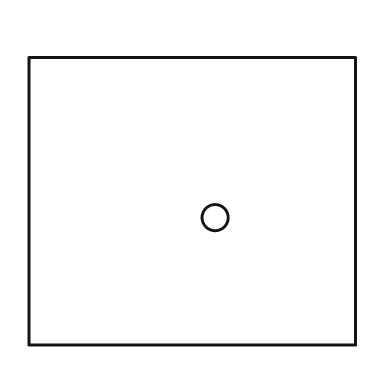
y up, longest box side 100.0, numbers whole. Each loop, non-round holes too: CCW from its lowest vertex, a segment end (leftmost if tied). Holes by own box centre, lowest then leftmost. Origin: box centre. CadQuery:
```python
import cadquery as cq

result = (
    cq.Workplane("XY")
    .moveTo(-50.0, -44.0)
    .lineTo(50.0, -44.0)
    .lineTo(50.0, 44.0)
    .lineTo(-50.0, 44.0)
    .close()
    .moveTo(7.0, -5.0)
    .circle(4.0)
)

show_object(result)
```